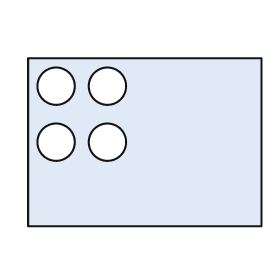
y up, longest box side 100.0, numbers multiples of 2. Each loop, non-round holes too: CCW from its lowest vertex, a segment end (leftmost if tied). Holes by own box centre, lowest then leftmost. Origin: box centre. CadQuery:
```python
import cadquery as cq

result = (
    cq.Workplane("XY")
    .moveTo(-50.0, -36.0)
    .lineTo(50.0, -36.0)
    .lineTo(50.0, 36.0)
    .lineTo(-50.0, 36.0)
    .close()
    .moveTo(-38.0, 0.0)
    .circle(8.0)
    .moveTo(-16.0, 0.0)
    .circle(8.0)
    .moveTo(-38.0, 24.0)
    .circle(8.0)
    .moveTo(-16.0, 24.0)
    .circle(8.0)
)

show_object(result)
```